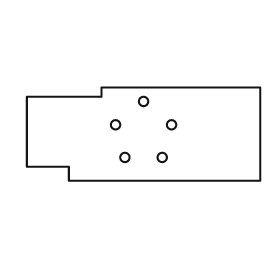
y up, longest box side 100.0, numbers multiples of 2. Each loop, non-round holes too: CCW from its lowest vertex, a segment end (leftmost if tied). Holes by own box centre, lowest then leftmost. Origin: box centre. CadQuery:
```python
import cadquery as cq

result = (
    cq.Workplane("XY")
    .moveTo(-32.0, -20.0)
    .lineTo(50.0, -20.0)
    .lineTo(50.0, 20.0)
    .lineTo(-18.0, 20.0)
    .lineTo(-18.0, 16.0)
    .lineTo(-50.0, 16.0)
    .lineTo(-50.0, -14.0)
    .lineTo(-32.0, -14.0)
    .close()
    .moveTo(-8.0, -10.0)
    .circle(2.0)
    .moveTo(8.0, -10.0)
    .circle(2.0)
    .moveTo(-12.0, 4.0)
    .circle(2.0)
    .moveTo(12.0, 4.0)
    .circle(2.0)
    .moveTo(0.0, 14.0)
    .circle(2.0)
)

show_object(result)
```